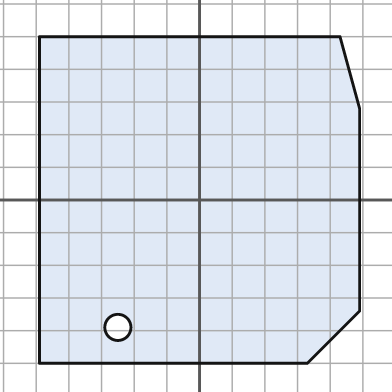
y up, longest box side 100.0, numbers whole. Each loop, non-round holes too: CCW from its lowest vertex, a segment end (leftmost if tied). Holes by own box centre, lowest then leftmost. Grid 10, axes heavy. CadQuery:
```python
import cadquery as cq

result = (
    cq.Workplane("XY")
    .moveTo(-49.0, -50.0)
    .lineTo(33.0, -50.0)
    .lineTo(49.0, -34.0)
    .lineTo(49.0, 28.0)
    .lineTo(43.0, 50.0)
    .lineTo(-49.0, 50.0)
    .close()
    .moveTo(-25.0, -39.0)
    .circle(4.0)
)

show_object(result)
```